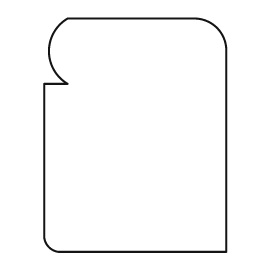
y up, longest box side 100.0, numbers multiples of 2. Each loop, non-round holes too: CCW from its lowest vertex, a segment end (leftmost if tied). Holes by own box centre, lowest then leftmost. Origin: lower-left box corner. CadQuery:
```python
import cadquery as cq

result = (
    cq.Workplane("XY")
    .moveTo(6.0, 0.0)
    .lineTo(78.0, 0.0)
    .lineTo(78.0, 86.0)
    .threePointArc((74.0, 96.0), (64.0, 100.0))
    .lineTo(10.0, 100.0)
    .threePointArc((2.0, 86.0), (10.0, 72.0))
    .lineTo(0.0, 72.0)
    .lineTo(0.0, 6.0)
    .threePointArc((2.0, 2.0), (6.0, 0.0))
    .close()
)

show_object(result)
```